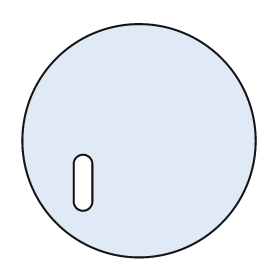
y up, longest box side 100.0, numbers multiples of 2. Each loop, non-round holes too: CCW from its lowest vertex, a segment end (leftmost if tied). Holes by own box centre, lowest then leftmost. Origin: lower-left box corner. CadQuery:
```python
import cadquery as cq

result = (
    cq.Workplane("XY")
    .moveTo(50.0, 50.0)
    .circle(50.0)
    .moveTo(22.0, 24.0)
    .threePointArc((26.0, 20.0), (30.0, 24.0))
    .lineTo(30.0, 40.0)
    .threePointArc((26.0, 44.0), (22.0, 40.0))
    .close()
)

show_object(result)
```